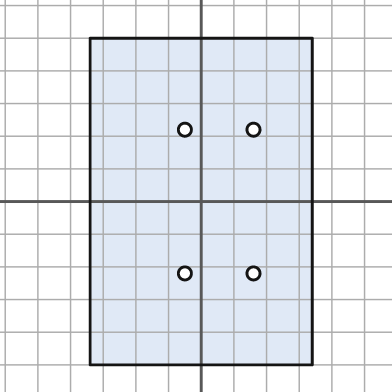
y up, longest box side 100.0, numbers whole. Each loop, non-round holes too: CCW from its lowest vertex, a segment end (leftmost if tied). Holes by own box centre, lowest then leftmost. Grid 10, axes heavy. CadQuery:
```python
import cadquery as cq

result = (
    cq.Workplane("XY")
    .moveTo(-34.0, -50.0)
    .lineTo(34.0, -50.0)
    .lineTo(34.0, 50.0)
    .lineTo(-34.0, 50.0)
    .close()
    .moveTo(-5.0, -22.0)
    .circle(2.0)
    .moveTo(16.0, -22.0)
    .circle(2.0)
    .moveTo(-5.0, 22.0)
    .circle(2.0)
    .moveTo(16.0, 22.0)
    .circle(2.0)
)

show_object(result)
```